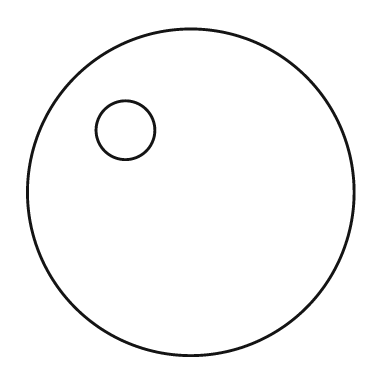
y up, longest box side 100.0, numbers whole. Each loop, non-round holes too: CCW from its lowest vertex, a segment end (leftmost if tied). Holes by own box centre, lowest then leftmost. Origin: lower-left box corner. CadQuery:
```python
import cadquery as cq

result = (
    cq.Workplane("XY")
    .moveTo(50.0, 50.0)
    .circle(50.0)
    .moveTo(30.0, 69.0)
    .circle(9.0)
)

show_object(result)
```